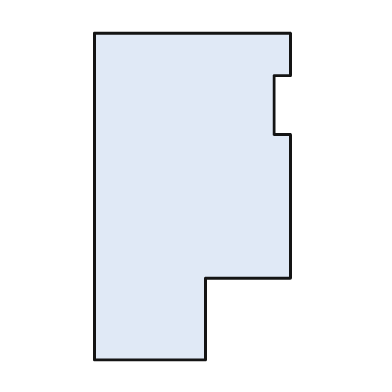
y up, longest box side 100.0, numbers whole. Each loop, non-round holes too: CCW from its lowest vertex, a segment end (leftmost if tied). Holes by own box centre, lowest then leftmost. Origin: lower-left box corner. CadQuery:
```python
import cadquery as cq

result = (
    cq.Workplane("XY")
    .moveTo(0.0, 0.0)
    .lineTo(34.0, 0.0)
    .lineTo(34.0, 25.0)
    .lineTo(60.0, 25.0)
    .lineTo(60.0, 69.0)
    .lineTo(55.0, 69.0)
    .lineTo(55.0, 87.0)
    .lineTo(60.0, 87.0)
    .lineTo(60.0, 100.0)
    .lineTo(0.0, 100.0)
    .close()
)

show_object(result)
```